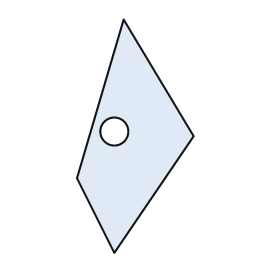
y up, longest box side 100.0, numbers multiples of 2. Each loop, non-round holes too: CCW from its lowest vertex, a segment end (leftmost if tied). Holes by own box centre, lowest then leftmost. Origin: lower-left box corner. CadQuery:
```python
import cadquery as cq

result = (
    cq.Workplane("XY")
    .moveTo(16.0, 0.0)
    .lineTo(50.0, 50.0)
    .lineTo(20.0, 100.0)
    .lineTo(0.0, 32.0)
    .close()
    .moveTo(16.0, 52.0)
    .circle(6.0)
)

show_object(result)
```